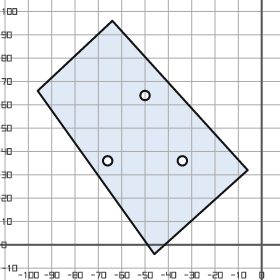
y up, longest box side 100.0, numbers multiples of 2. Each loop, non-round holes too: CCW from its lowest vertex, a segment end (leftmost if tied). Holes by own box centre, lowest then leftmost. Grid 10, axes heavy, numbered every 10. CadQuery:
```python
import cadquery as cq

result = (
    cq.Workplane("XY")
    .moveTo(-46.0, -4.0)
    .lineTo(-6.0, 32.0)
    .lineTo(-64.0, 96.0)
    .lineTo(-96.0, 66.0)
    .close()
    .moveTo(-66.0, 36.0)
    .circle(2.0)
    .moveTo(-34.0, 36.0)
    .circle(2.0)
    .moveTo(-50.0, 64.0)
    .circle(2.0)
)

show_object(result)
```